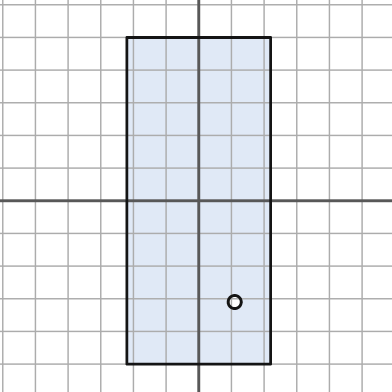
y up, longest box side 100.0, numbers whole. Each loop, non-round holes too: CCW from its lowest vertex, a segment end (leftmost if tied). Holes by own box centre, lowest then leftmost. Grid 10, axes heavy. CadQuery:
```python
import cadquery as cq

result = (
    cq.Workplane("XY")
    .moveTo(-22.0, -50.0)
    .lineTo(22.0, -50.0)
    .lineTo(22.0, 50.0)
    .lineTo(-22.0, 50.0)
    .close()
    .moveTo(11.0, -31.0)
    .circle(2.0)
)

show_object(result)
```